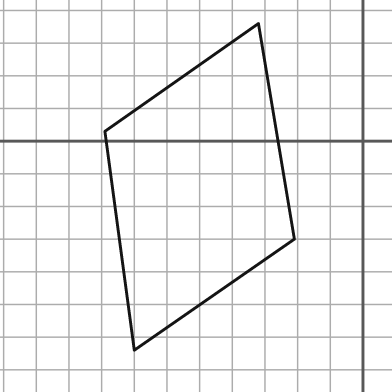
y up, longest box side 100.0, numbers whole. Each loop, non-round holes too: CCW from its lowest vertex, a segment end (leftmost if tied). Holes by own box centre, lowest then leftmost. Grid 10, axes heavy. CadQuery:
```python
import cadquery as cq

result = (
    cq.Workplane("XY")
    .moveTo(-70.0, -64.0)
    .lineTo(-21.0, -30.0)
    .lineTo(-32.0, 36.0)
    .lineTo(-79.0, 3.0)
    .close()
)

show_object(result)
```